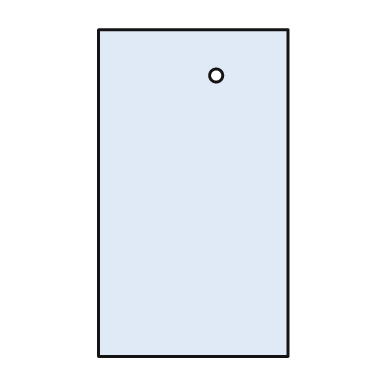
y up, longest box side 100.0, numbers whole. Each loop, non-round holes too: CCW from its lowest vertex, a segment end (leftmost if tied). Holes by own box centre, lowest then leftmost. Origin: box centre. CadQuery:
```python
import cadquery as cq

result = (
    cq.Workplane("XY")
    .moveTo(-29.0, -50.0)
    .lineTo(29.0, -50.0)
    .lineTo(29.0, 50.0)
    .lineTo(-29.0, 50.0)
    .close()
    .moveTo(7.0, 36.0)
    .circle(2.0)
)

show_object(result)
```